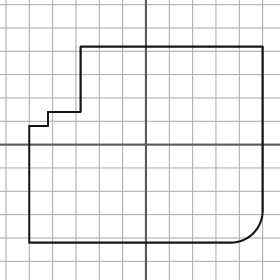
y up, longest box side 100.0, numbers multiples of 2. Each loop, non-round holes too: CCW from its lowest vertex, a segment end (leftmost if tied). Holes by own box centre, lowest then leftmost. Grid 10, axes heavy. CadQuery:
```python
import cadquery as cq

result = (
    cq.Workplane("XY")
    .moveTo(-50.0, -42.0)
    .lineTo(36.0, -42.0)
    .threePointArc((46.0, -38.0), (50.0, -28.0))
    .lineTo(50.0, 42.0)
    .lineTo(-28.0, 42.0)
    .lineTo(-28.0, 14.0)
    .lineTo(-42.0, 14.0)
    .lineTo(-42.0, 8.0)
    .lineTo(-50.0, 8.0)
    .close()
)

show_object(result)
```